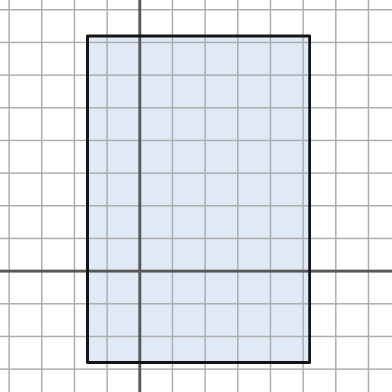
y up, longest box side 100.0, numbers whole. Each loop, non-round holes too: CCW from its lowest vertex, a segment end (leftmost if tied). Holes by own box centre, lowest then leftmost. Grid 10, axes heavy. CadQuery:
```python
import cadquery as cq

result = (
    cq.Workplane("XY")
    .moveTo(-16.0, -28.0)
    .lineTo(52.0, -28.0)
    .lineTo(52.0, 72.0)
    .lineTo(-16.0, 72.0)
    .close()
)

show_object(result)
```